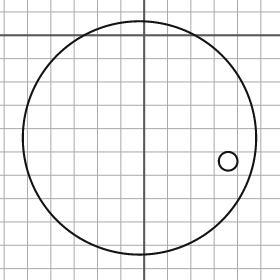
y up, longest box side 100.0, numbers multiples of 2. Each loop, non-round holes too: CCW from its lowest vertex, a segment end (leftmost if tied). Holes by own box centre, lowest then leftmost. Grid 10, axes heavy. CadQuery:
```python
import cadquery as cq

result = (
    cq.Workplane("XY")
    .moveTo(-2.0, -44.0)
    .circle(50.0)
    .moveTo(36.0, -54.0)
    .circle(4.0)
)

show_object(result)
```